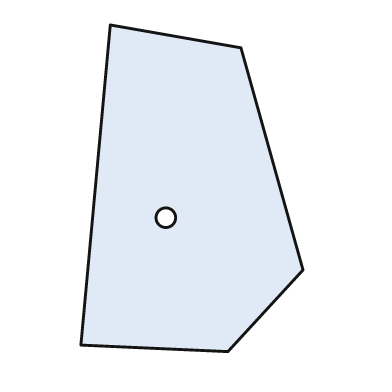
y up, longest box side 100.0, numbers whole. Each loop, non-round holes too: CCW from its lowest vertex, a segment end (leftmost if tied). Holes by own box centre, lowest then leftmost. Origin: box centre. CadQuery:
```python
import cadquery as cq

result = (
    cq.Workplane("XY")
    .moveTo(11.0, -50.0)
    .lineTo(34.0, -25.0)
    .lineTo(15.0, 43.0)
    .lineTo(-25.0, 50.0)
    .lineTo(-34.0, -48.0)
    .close()
    .moveTo(-8.0, -9.0)
    .circle(3.0)
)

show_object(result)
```